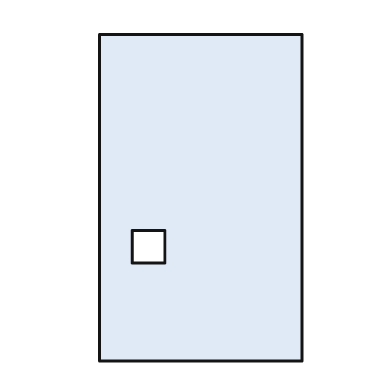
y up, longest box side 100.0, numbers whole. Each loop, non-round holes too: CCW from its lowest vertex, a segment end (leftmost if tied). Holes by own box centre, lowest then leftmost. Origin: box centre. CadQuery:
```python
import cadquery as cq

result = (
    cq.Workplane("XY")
    .moveTo(-31.0, -50.0)
    .lineTo(31.0, -50.0)
    .lineTo(31.0, 50.0)
    .lineTo(-31.0, 50.0)
    .close()
    .moveTo(-21.0, -20.0)
    .lineTo(-11.0, -20.0)
    .lineTo(-11.0, -10.0)
    .lineTo(-21.0, -10.0)
    .close()
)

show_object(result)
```